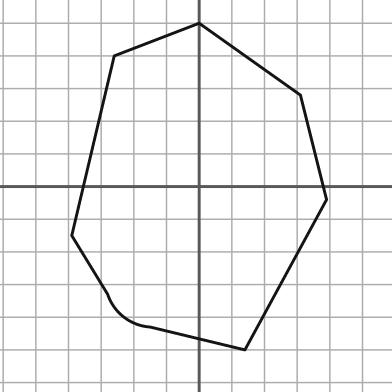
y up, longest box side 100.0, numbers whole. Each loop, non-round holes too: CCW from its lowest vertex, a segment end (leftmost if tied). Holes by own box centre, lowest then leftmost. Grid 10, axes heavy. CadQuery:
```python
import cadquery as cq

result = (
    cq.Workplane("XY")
    .moveTo(14.0, -50.0)
    .lineTo(39.0, -4.0)
    .lineTo(31.0, 28.0)
    .lineTo(0.0, 50.0)
    .lineTo(-26.0, 40.0)
    .lineTo(-39.0, -15.0)
    .lineTo(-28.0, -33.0)
    .threePointArc((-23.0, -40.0), (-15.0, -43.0))
    .close()
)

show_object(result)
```